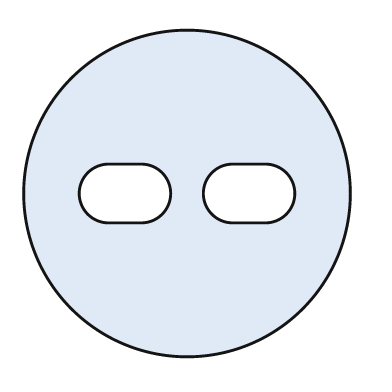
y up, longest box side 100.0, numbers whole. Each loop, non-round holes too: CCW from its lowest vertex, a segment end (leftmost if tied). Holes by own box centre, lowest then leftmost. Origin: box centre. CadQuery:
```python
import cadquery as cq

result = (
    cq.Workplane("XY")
    .moveTo(0.0, 0.0)
    .circle(50.0)
    .moveTo(-24.0, -9.0)
    .lineTo(-14.0, -9.0)
    .threePointArc((-5.0, 0.0), (-14.0, 9.0))
    .lineTo(-24.0, 9.0)
    .threePointArc((-33.0, 0.0), (-24.0, -9.0))
    .close()
    .moveTo(14.0, -9.0)
    .lineTo(24.0, -9.0)
    .threePointArc((33.0, 0.0), (24.0, 9.0))
    .lineTo(14.0, 9.0)
    .threePointArc((5.0, 0.0), (14.0, -9.0))
    .close()
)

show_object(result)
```